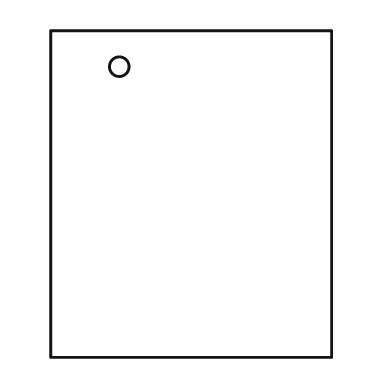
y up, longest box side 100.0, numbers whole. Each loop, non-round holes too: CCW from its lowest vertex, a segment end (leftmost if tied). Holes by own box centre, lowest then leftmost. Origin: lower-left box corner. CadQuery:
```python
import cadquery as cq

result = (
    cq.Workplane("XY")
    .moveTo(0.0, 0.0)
    .lineTo(86.0, 0.0)
    .lineTo(86.0, 100.0)
    .lineTo(0.0, 100.0)
    .close()
    .moveTo(21.0, 89.0)
    .circle(3.0)
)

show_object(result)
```